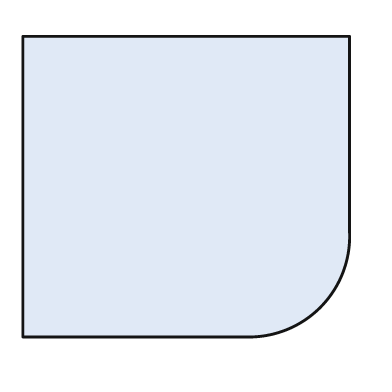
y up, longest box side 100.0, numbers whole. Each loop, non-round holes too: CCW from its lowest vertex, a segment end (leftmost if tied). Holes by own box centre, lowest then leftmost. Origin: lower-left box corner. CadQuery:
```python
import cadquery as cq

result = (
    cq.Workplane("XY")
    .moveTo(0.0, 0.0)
    .lineTo(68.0, 0.0)
    .threePointArc((91.0, 9.0), (100.0, 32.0))
    .lineTo(100.0, 92.0)
    .lineTo(0.0, 92.0)
    .close()
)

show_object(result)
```